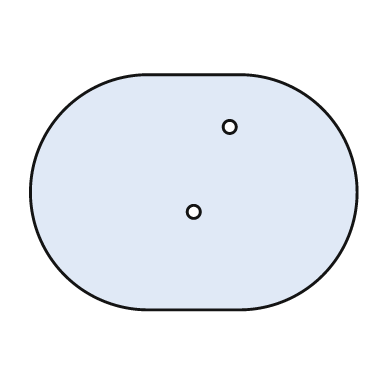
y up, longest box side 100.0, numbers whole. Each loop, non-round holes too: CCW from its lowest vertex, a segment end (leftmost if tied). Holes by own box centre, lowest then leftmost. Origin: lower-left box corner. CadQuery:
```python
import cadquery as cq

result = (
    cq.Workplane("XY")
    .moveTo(36.0, 0.0)
    .lineTo(64.0, 0.0)
    .threePointArc((100.0, 36.0), (64.0, 72.0))
    .lineTo(36.0, 72.0)
    .threePointArc((0.0, 36.0), (36.0, 0.0))
    .close()
    .moveTo(50.0, 30.0)
    .circle(2.0)
    .moveTo(61.0, 56.0)
    .circle(2.0)
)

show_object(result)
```